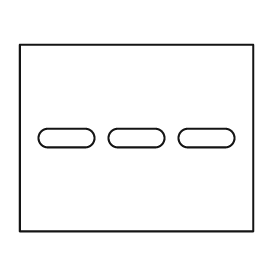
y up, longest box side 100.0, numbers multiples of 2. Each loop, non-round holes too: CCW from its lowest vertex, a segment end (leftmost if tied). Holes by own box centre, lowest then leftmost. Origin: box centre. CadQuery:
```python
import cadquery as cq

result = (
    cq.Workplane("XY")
    .moveTo(-50.0, -40.0)
    .lineTo(50.0, -40.0)
    .lineTo(50.0, 40.0)
    .lineTo(-50.0, 40.0)
    .close()
    .moveTo(-38.0, -4.0)
    .lineTo(-22.0, -4.0)
    .threePointArc((-18.0, 0.0), (-22.0, 4.0))
    .lineTo(-38.0, 4.0)
    .threePointArc((-42.0, 0.0), (-38.0, -4.0))
    .close()
    .moveTo(-8.0, -4.0)
    .lineTo(8.0, -4.0)
    .threePointArc((12.0, 0.0), (8.0, 4.0))
    .lineTo(-8.0, 4.0)
    .threePointArc((-12.0, 0.0), (-8.0, -4.0))
    .close()
    .moveTo(22.0, -4.0)
    .lineTo(38.0, -4.0)
    .threePointArc((42.0, 0.0), (38.0, 4.0))
    .lineTo(22.0, 4.0)
    .threePointArc((18.0, 0.0), (22.0, -4.0))
    .close()
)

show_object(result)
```